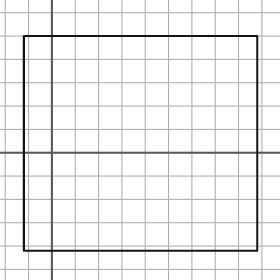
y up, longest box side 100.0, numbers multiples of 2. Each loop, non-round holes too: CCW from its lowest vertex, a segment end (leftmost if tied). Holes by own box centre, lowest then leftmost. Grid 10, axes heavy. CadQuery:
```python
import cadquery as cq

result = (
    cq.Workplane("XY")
    .moveTo(-12.0, -42.0)
    .lineTo(88.0, -42.0)
    .lineTo(88.0, 50.0)
    .lineTo(-12.0, 50.0)
    .close()
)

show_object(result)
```